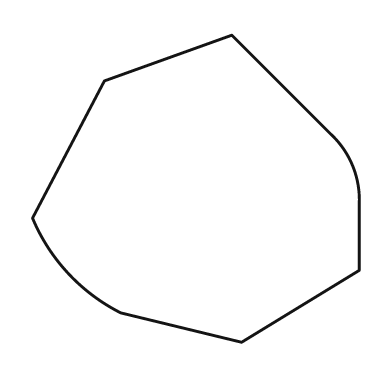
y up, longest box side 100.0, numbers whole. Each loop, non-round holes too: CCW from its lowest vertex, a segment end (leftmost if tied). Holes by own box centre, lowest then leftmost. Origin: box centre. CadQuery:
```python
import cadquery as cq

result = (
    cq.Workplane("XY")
    .moveTo(14.0, -47.0)
    .lineTo(50.0, -25.0)
    .lineTo(50.0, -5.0)
    .threePointArc((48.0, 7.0), (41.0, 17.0))
    .lineTo(11.0, 47.0)
    .lineTo(-28.0, 33.0)
    .lineTo(-50.0, -9.0)
    .threePointArc((-39.0, -26.0), (-23.0, -38.0))
    .close()
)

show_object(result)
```